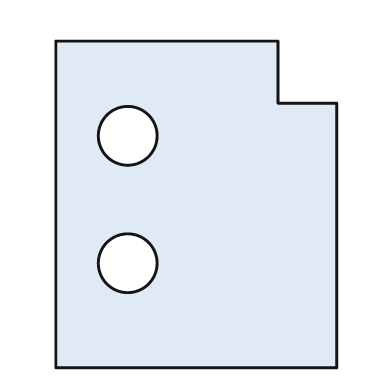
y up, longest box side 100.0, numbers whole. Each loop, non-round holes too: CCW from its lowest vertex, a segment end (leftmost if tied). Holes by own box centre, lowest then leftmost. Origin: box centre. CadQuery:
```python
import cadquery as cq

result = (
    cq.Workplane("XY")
    .moveTo(-43.0, -50.0)
    .lineTo(43.0, -50.0)
    .lineTo(43.0, 31.0)
    .lineTo(25.0, 31.0)
    .lineTo(25.0, 50.0)
    .lineTo(-43.0, 50.0)
    .close()
    .moveTo(-21.0, -18.0)
    .circle(9.0)
    .moveTo(-21.0, 21.0)
    .circle(9.0)
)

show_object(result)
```